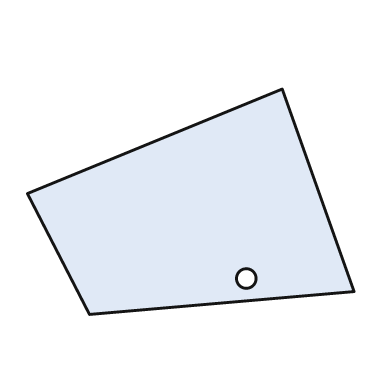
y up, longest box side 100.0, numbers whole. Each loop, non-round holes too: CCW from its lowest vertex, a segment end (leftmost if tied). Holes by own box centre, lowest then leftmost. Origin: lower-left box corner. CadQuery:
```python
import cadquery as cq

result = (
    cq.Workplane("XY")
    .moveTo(19.0, 0.0)
    .lineTo(100.0, 7.0)
    .lineTo(78.0, 69.0)
    .lineTo(0.0, 37.0)
    .close()
    .moveTo(67.0, 11.0)
    .circle(3.0)
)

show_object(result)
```